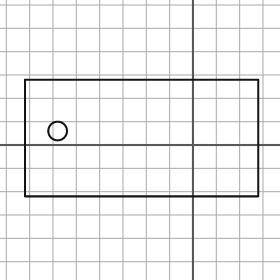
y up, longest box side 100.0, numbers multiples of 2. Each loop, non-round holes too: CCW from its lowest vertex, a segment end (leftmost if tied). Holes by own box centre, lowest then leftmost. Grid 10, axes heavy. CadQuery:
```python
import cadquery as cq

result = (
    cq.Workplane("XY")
    .moveTo(-72.0, -22.0)
    .lineTo(28.0, -22.0)
    .lineTo(28.0, 28.0)
    .lineTo(-72.0, 28.0)
    .close()
    .moveTo(-58.0, 6.0)
    .circle(4.0)
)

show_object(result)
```